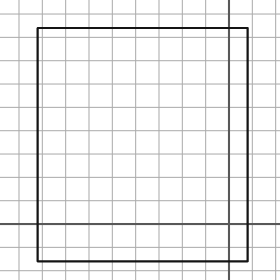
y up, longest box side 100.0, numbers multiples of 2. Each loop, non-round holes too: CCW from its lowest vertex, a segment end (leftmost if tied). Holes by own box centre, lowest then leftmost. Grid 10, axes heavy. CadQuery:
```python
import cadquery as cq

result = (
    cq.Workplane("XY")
    .moveTo(-82.0, -16.0)
    .lineTo(8.0, -16.0)
    .lineTo(8.0, 84.0)
    .lineTo(-82.0, 84.0)
    .close()
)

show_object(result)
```